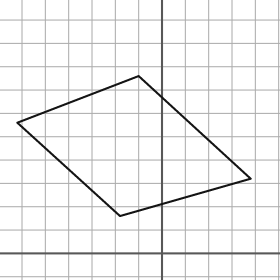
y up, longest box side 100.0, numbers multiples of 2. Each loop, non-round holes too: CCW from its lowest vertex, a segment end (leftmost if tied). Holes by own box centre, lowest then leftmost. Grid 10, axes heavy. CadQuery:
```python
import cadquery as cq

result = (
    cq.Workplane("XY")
    .moveTo(-18.0, 16.0)
    .lineTo(38.0, 32.0)
    .lineTo(-10.0, 76.0)
    .lineTo(-62.0, 56.0)
    .close()
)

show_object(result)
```